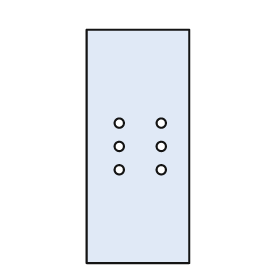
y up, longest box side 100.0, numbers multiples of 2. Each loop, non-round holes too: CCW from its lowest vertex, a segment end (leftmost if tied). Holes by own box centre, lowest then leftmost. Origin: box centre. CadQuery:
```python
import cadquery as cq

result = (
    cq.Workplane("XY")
    .moveTo(-22.0, -50.0)
    .lineTo(22.0, -50.0)
    .lineTo(22.0, 50.0)
    .lineTo(-22.0, 50.0)
    .close()
    .moveTo(-8.0, -10.0)
    .circle(2.0)
    .moveTo(10.0, -10.0)
    .circle(2.0)
    .moveTo(-8.0, 0.0)
    .circle(2.0)
    .moveTo(10.0, 0.0)
    .circle(2.0)
    .moveTo(-8.0, 10.0)
    .circle(2.0)
    .moveTo(10.0, 10.0)
    .circle(2.0)
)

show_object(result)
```